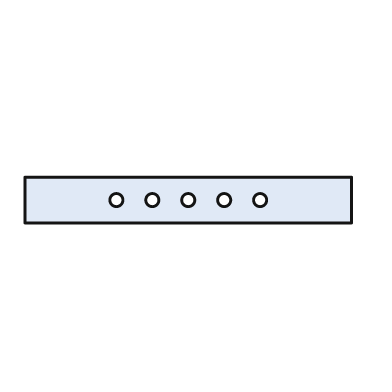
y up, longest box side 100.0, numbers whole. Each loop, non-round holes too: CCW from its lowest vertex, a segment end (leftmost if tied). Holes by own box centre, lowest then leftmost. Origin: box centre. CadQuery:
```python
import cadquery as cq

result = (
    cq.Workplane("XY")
    .moveTo(-50.0, -7.0)
    .lineTo(50.0, -7.0)
    .lineTo(50.0, 7.0)
    .lineTo(-50.0, 7.0)
    .close()
    .moveTo(-22.0, 0.0)
    .circle(2.0)
    .moveTo(-11.0, 0.0)
    .circle(2.0)
    .moveTo(0.0, 0.0)
    .circle(2.0)
    .moveTo(11.0, 0.0)
    .circle(2.0)
    .moveTo(22.0, 0.0)
    .circle(2.0)
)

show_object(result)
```